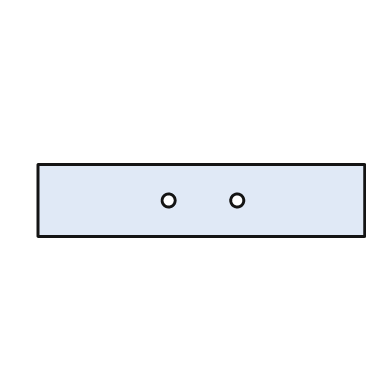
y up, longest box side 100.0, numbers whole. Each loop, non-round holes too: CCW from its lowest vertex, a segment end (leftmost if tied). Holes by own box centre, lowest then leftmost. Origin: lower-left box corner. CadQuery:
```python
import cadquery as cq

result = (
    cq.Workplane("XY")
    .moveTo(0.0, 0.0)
    .lineTo(100.0, 0.0)
    .lineTo(100.0, 22.0)
    .lineTo(0.0, 22.0)
    .close()
    .moveTo(40.0, 11.0)
    .circle(2.0)
    .moveTo(61.0, 11.0)
    .circle(2.0)
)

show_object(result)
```